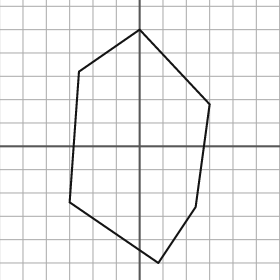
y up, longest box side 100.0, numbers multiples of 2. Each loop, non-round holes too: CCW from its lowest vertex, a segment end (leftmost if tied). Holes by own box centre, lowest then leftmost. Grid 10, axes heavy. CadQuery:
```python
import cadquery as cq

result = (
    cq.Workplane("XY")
    .moveTo(8.0, -50.0)
    .lineTo(24.0, -26.0)
    .lineTo(30.0, 18.0)
    .lineTo(0.0, 50.0)
    .lineTo(-26.0, 32.0)
    .lineTo(-30.0, -24.0)
    .close()
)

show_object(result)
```